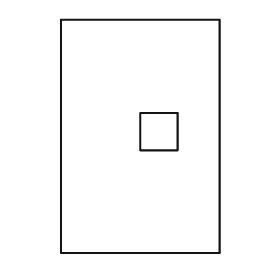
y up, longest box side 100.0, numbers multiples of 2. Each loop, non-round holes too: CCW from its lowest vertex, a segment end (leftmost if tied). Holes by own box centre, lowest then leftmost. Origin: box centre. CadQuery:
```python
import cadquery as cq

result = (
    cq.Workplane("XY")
    .moveTo(-34.0, -50.0)
    .lineTo(34.0, -50.0)
    .lineTo(34.0, 50.0)
    .lineTo(-34.0, 50.0)
    .close()
    .moveTo(0.0, -6.0)
    .lineTo(16.0, -6.0)
    .lineTo(16.0, 10.0)
    .lineTo(0.0, 10.0)
    .close()
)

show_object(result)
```